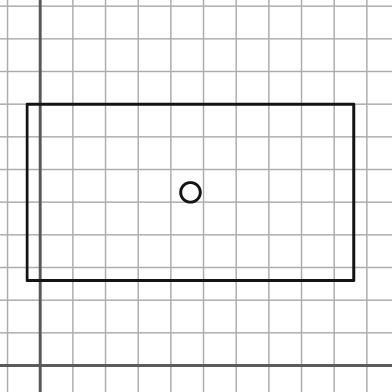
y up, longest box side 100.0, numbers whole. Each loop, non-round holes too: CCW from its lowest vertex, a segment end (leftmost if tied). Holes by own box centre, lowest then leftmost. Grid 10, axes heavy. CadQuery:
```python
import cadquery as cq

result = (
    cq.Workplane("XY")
    .moveTo(-4.0, 26.0)
    .lineTo(96.0, 26.0)
    .lineTo(96.0, 80.0)
    .lineTo(-4.0, 80.0)
    .close()
    .moveTo(46.0, 53.0)
    .circle(3.0)
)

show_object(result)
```